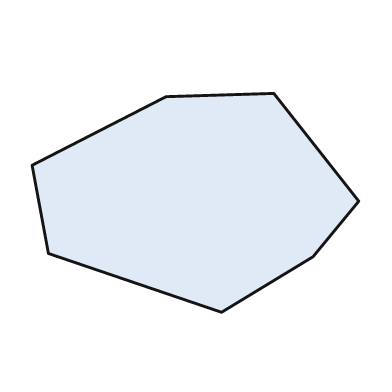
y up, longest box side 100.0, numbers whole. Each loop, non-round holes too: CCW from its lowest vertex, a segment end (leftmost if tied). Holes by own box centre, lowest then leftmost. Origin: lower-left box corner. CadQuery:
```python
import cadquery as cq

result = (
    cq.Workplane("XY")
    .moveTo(58.0, 0.0)
    .lineTo(86.0, 17.0)
    .lineTo(100.0, 34.0)
    .lineTo(74.0, 67.0)
    .lineTo(41.0, 66.0)
    .lineTo(0.0, 45.0)
    .lineTo(5.0, 18.0)
    .close()
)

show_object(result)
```